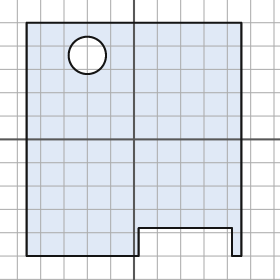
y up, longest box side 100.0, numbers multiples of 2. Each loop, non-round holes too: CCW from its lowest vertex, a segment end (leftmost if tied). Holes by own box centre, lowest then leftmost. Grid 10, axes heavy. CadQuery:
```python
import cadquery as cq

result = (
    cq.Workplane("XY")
    .moveTo(-46.0, -50.0)
    .lineTo(2.0, -50.0)
    .lineTo(2.0, -38.0)
    .lineTo(42.0, -38.0)
    .lineTo(42.0, -50.0)
    .lineTo(46.0, -50.0)
    .lineTo(46.0, 50.0)
    .lineTo(-46.0, 50.0)
    .close()
    .moveTo(-20.0, 36.0)
    .circle(8.0)
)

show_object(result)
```